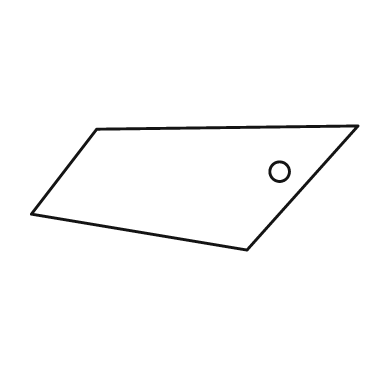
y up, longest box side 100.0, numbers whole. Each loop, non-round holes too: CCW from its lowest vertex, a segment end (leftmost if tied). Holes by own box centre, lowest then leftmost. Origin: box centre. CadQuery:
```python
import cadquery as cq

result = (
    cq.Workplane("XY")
    .moveTo(16.0, -19.0)
    .lineTo(50.0, 19.0)
    .lineTo(-30.0, 18.0)
    .lineTo(-50.0, -8.0)
    .close()
    .moveTo(26.0, 5.0)
    .circle(3.0)
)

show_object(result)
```